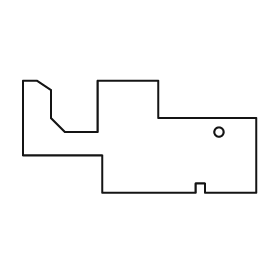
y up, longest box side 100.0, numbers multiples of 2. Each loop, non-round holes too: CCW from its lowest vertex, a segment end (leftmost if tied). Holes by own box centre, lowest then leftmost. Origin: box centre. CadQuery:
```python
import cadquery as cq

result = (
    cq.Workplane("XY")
    .moveTo(-16.0, -24.0)
    .lineTo(24.0, -24.0)
    .lineTo(24.0, -20.0)
    .lineTo(28.0, -20.0)
    .lineTo(28.0, -24.0)
    .lineTo(50.0, -24.0)
    .lineTo(50.0, 8.0)
    .lineTo(8.0, 8.0)
    .lineTo(8.0, 24.0)
    .lineTo(-18.0, 24.0)
    .lineTo(-18.0, 2.0)
    .lineTo(-32.0, 2.0)
    .lineTo(-38.0, 8.0)
    .lineTo(-38.0, 20.0)
    .lineTo(-44.0, 24.0)
    .lineTo(-50.0, 24.0)
    .lineTo(-50.0, -8.0)
    .lineTo(-16.0, -8.0)
    .close()
    .moveTo(34.0, 2.0)
    .circle(2.0)
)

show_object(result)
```